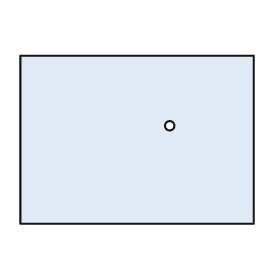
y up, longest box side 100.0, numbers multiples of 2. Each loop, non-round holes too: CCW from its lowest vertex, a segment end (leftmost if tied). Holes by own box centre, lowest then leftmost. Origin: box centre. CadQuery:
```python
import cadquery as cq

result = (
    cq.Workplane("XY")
    .moveTo(-50.0, -36.0)
    .lineTo(50.0, -36.0)
    .lineTo(50.0, 36.0)
    .lineTo(-50.0, 36.0)
    .close()
    .moveTo(14.0, 6.0)
    .circle(2.0)
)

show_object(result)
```